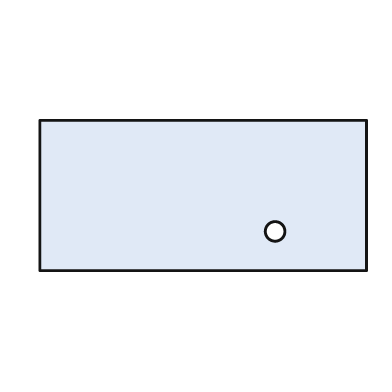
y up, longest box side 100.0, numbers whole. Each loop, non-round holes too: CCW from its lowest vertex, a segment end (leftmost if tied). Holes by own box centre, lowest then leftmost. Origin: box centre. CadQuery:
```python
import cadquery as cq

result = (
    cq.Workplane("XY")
    .moveTo(-50.0, -23.0)
    .lineTo(50.0, -23.0)
    .lineTo(50.0, 23.0)
    .lineTo(-50.0, 23.0)
    .close()
    .moveTo(22.0, -11.0)
    .circle(3.0)
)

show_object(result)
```